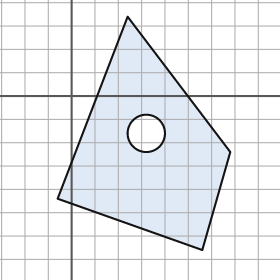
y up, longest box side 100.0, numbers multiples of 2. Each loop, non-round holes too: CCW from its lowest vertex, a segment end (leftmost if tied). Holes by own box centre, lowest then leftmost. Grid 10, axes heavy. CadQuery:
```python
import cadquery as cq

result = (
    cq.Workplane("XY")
    .moveTo(56.0, -66.0)
    .lineTo(68.0, -24.0)
    .lineTo(24.0, 34.0)
    .lineTo(-6.0, -44.0)
    .close()
    .moveTo(32.0, -16.0)
    .circle(8.0)
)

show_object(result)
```